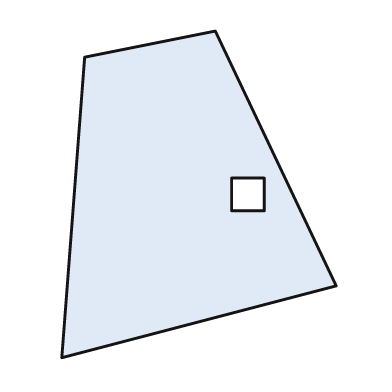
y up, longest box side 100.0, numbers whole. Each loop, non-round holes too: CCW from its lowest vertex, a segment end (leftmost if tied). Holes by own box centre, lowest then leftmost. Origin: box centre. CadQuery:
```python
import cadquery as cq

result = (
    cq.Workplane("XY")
    .moveTo(-42.0, -50.0)
    .lineTo(42.0, -28.0)
    .lineTo(5.0, 50.0)
    .lineTo(-35.0, 42.0)
    .close()
    .moveTo(10.0, -5.0)
    .lineTo(20.0, -5.0)
    .lineTo(20.0, 5.0)
    .lineTo(10.0, 5.0)
    .close()
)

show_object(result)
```